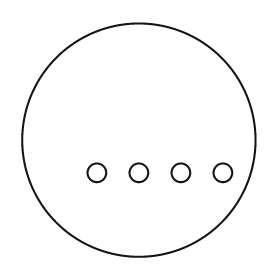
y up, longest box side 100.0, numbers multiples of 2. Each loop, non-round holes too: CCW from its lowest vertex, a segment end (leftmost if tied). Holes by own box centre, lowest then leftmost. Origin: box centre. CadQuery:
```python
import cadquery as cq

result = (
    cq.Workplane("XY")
    .moveTo(0.0, 0.0)
    .circle(50.0)
    .moveTo(-18.0, -14.0)
    .circle(4.0)
    .moveTo(0.0, -14.0)
    .circle(4.0)
    .moveTo(18.0, -14.0)
    .circle(4.0)
    .moveTo(36.0, -14.0)
    .circle(4.0)
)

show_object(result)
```